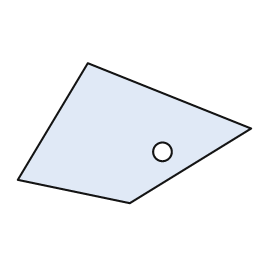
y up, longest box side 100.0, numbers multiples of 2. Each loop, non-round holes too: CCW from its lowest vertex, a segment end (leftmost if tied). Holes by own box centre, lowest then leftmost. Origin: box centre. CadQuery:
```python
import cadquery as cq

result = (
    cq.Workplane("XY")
    .moveTo(-2.0, -30.0)
    .lineTo(50.0, 2.0)
    .lineTo(-20.0, 30.0)
    .lineTo(-50.0, -20.0)
    .close()
    .moveTo(12.0, -8.0)
    .circle(4.0)
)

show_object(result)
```